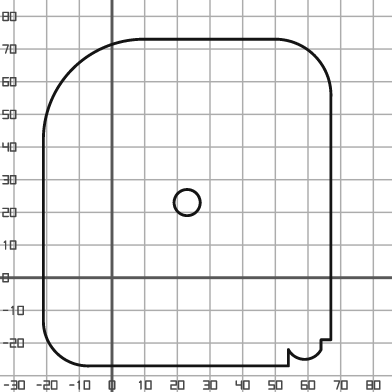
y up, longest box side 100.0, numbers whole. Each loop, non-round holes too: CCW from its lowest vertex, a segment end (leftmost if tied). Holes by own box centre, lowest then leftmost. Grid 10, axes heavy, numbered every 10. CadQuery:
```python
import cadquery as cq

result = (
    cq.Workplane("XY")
    .moveTo(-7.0, -27.0)
    .lineTo(54.0, -27.0)
    .lineTo(54.0, -22.0)
    .threePointArc((59.0, -25.0), (64.0, -22.0))
    .lineTo(64.0, -19.0)
    .lineTo(67.0, -19.0)
    .lineTo(67.0, 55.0)
    .threePointArc((62.0, 68.0), (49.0, 73.0))
    .lineTo(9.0, 73.0)
    .threePointArc((-12.0, 64.0), (-21.0, 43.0))
    .lineTo(-21.0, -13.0)
    .threePointArc((-17.0, -23.0), (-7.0, -27.0))
    .close()
    .moveTo(23.0, 23.0)
    .circle(4.0)
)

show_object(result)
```